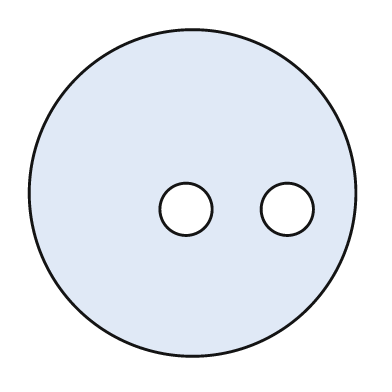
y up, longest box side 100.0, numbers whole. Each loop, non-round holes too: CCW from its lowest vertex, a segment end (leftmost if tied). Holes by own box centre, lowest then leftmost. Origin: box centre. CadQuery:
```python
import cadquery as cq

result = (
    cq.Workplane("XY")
    .moveTo(0.0, 0.0)
    .circle(50.0)
    .moveTo(-2.0, -5.0)
    .circle(8.0)
    .moveTo(29.0, -5.0)
    .circle(8.0)
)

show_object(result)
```